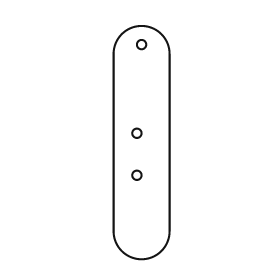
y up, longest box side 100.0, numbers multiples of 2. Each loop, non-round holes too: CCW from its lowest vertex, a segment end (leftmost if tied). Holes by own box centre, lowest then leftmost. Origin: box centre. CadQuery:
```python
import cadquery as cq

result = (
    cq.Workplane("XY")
    .moveTo(-12.0, -38.0)
    .threePointArc((0.0, -50.0), (12.0, -38.0))
    .lineTo(12.0, 38.0)
    .threePointArc((0.0, 50.0), (-12.0, 38.0))
    .close()
    .moveTo(-2.0, -14.0)
    .circle(2.0)
    .moveTo(-2.0, 4.0)
    .circle(2.0)
    .moveTo(0.0, 42.0)
    .circle(2.0)
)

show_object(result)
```